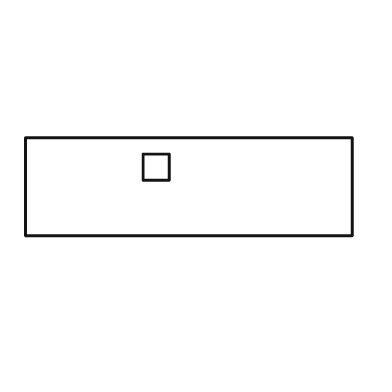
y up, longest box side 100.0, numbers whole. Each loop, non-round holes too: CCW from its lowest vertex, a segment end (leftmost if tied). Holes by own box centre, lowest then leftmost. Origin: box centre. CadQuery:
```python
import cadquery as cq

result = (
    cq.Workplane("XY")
    .moveTo(-50.0, -15.0)
    .lineTo(50.0, -15.0)
    .lineTo(50.0, 15.0)
    .lineTo(-50.0, 15.0)
    .close()
    .moveTo(-14.0, 2.0)
    .lineTo(-6.0, 2.0)
    .lineTo(-6.0, 10.0)
    .lineTo(-14.0, 10.0)
    .close()
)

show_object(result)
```